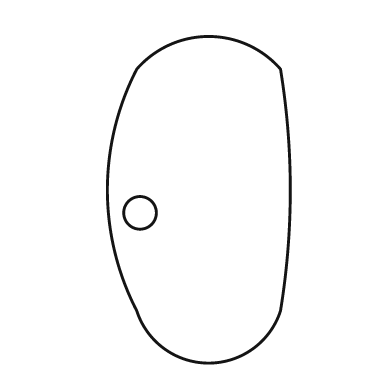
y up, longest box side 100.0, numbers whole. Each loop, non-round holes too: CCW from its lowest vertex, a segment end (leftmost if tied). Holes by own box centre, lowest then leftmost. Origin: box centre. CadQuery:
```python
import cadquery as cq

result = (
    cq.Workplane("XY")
    .moveTo(-19.0, -34.0)
    .threePointArc((3.0, -50.0), (25.0, -34.0))
    .threePointArc((28.0, 3.0), (25.0, 40.0))
    .threePointArc((3.0, 50.0), (-19.0, 40.0))
    .threePointArc((-28.0, 3.0), (-19.0, -34.0))
    .close()
    .moveTo(-18.0, -4.0)
    .circle(5.0)
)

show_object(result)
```